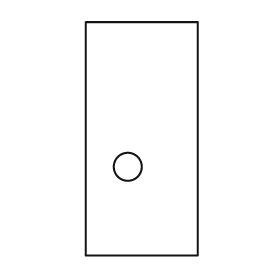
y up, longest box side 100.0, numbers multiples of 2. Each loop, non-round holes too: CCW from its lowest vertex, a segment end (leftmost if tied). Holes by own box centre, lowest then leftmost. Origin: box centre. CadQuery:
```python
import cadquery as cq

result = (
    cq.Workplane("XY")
    .moveTo(-24.0, -50.0)
    .lineTo(24.0, -50.0)
    .lineTo(24.0, 50.0)
    .lineTo(-24.0, 50.0)
    .close()
    .moveTo(-6.0, -12.0)
    .circle(6.0)
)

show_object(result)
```